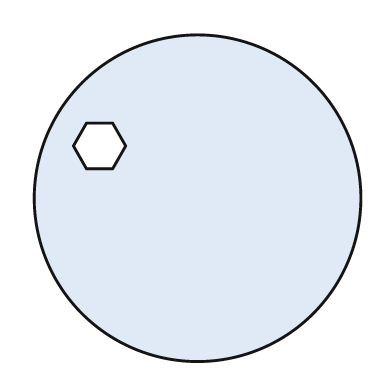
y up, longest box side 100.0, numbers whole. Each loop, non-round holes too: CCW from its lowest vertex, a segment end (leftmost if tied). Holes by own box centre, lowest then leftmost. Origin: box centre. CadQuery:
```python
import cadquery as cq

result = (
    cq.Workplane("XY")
    .moveTo(0.0, 0.0)
    .circle(50.0)
    .moveTo(-34.0, 9.0)
    .lineTo(-26.0, 9.0)
    .lineTo(-22.0, 16.0)
    .lineTo(-26.0, 23.0)
    .lineTo(-34.0, 23.0)
    .lineTo(-38.0, 16.0)
    .close()
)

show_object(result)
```